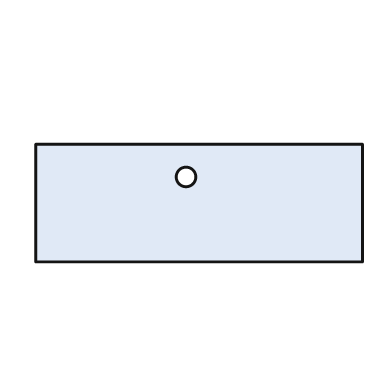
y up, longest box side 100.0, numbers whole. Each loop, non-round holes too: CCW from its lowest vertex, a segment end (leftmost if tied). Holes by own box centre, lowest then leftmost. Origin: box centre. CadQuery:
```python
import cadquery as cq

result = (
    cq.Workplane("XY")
    .moveTo(-50.0, -18.0)
    .lineTo(50.0, -18.0)
    .lineTo(50.0, 18.0)
    .lineTo(-50.0, 18.0)
    .close()
    .moveTo(-4.0, 8.0)
    .circle(3.0)
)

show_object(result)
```